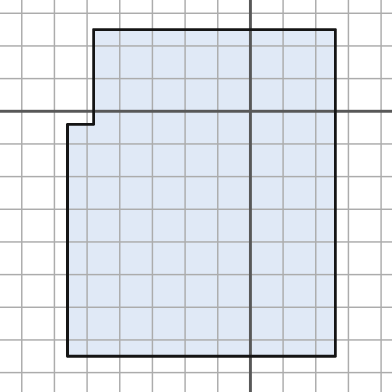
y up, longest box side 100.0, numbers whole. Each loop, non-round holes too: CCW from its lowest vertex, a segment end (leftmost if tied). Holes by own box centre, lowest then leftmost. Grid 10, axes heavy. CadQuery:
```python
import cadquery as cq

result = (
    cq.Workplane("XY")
    .moveTo(-56.0, -75.0)
    .lineTo(26.0, -75.0)
    .lineTo(26.0, 25.0)
    .lineTo(-48.0, 25.0)
    .lineTo(-48.0, -4.0)
    .lineTo(-56.0, -4.0)
    .close()
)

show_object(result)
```